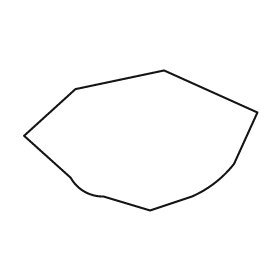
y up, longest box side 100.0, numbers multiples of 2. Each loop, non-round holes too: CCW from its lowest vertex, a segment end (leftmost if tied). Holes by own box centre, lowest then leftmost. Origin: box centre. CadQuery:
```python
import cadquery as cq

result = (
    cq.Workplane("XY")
    .moveTo(4.0, -30.0)
    .lineTo(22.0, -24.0)
    .threePointArc((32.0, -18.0), (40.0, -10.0))
    .lineTo(50.0, 12.0)
    .lineTo(10.0, 30.0)
    .lineTo(-28.0, 22.0)
    .lineTo(-50.0, 2.0)
    .lineTo(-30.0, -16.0)
    .threePointArc((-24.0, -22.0), (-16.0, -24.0))
    .close()
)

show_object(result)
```